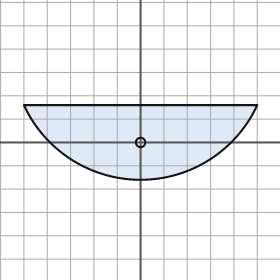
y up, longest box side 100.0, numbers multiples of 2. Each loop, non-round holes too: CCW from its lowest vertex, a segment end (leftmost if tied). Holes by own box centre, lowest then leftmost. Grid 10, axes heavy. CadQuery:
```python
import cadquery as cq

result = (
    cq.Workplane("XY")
    .moveTo(-50.0, 16.0)
    .threePointArc((0.0, -16.0), (50.0, 16.0))
    .close()
    .moveTo(0.0, 0.0)
    .circle(2.0)
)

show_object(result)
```